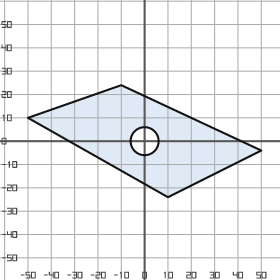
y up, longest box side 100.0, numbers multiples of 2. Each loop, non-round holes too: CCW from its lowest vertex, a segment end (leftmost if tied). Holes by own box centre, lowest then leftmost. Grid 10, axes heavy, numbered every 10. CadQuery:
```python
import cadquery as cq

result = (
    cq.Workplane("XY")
    .moveTo(10.0, -24.0)
    .lineTo(50.0, -4.0)
    .lineTo(-10.0, 24.0)
    .lineTo(-50.0, 10.0)
    .close()
    .moveTo(0.0, 0.0)
    .circle(6.0)
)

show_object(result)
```